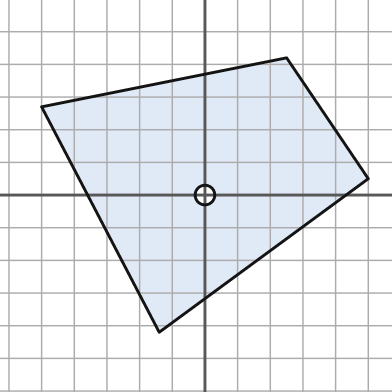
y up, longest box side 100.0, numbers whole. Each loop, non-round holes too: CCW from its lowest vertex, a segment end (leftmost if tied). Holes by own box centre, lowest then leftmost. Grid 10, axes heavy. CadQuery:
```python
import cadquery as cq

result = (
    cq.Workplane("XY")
    .moveTo(-14.0, -42.0)
    .lineTo(50.0, 5.0)
    .lineTo(25.0, 42.0)
    .lineTo(-50.0, 27.0)
    .close()
    .moveTo(0.0, 0.0)
    .circle(3.0)
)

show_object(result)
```